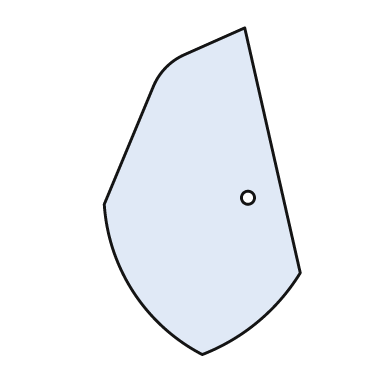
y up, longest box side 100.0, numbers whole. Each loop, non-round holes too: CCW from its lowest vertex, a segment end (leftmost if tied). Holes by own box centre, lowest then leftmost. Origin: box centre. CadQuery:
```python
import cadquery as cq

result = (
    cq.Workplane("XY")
    .moveTo(0.0, -50.0)
    .threePointArc((17.0, -40.0), (30.0, -25.0))
    .lineTo(13.0, 50.0)
    .lineTo(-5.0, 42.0)
    .threePointArc((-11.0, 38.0), (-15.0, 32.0))
    .lineTo(-30.0, -4.0)
    .threePointArc((-21.0, -31.0), (0.0, -50.0))
    .close()
    .moveTo(14.0, -2.0)
    .circle(2.0)
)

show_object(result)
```